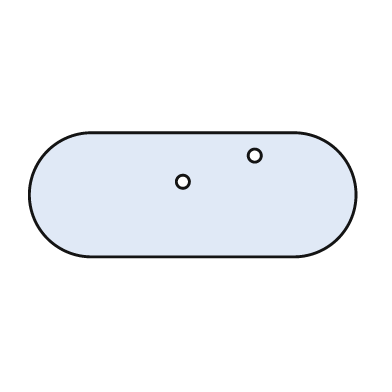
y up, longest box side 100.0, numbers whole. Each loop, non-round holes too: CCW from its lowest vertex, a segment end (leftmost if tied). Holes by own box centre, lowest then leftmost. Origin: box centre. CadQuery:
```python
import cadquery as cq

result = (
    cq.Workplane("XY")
    .moveTo(-31.0, -19.0)
    .lineTo(31.0, -19.0)
    .threePointArc((50.0, 0.0), (31.0, 19.0))
    .lineTo(-31.0, 19.0)
    .threePointArc((-50.0, 0.0), (-31.0, -19.0))
    .close()
    .moveTo(-3.0, 4.0)
    .circle(2.0)
    .moveTo(19.0, 12.0)
    .circle(2.0)
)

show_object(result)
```